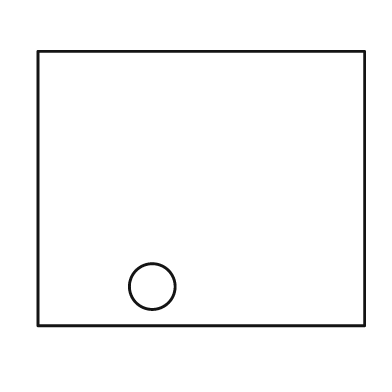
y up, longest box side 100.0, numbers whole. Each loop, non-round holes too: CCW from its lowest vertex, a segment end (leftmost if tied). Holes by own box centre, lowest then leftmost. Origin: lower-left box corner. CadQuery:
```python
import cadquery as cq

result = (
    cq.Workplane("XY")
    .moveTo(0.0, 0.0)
    .lineTo(100.0, 0.0)
    .lineTo(100.0, 84.0)
    .lineTo(0.0, 84.0)
    .close()
    .moveTo(35.0, 12.0)
    .circle(7.0)
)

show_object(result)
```